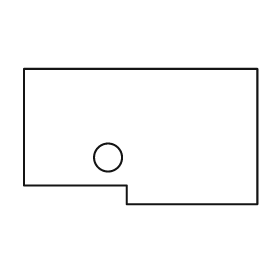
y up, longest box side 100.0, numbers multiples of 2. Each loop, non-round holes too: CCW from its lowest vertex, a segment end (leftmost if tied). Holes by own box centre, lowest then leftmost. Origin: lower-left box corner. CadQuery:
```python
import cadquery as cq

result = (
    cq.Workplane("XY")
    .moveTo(44.0, 0.0)
    .lineTo(100.0, 0.0)
    .lineTo(100.0, 58.0)
    .lineTo(0.0, 58.0)
    .lineTo(0.0, 8.0)
    .lineTo(44.0, 8.0)
    .close()
    .moveTo(36.0, 20.0)
    .circle(6.0)
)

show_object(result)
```